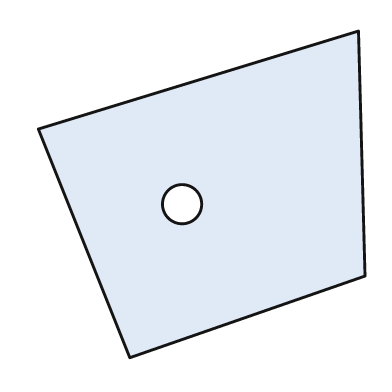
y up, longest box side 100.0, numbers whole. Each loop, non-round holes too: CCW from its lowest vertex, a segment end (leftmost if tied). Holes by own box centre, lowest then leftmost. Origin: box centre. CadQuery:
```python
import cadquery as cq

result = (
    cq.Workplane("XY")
    .moveTo(-22.0, -50.0)
    .lineTo(50.0, -25.0)
    .lineTo(48.0, 50.0)
    .lineTo(-50.0, 20.0)
    .close()
    .moveTo(-6.0, -3.0)
    .circle(6.0)
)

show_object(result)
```